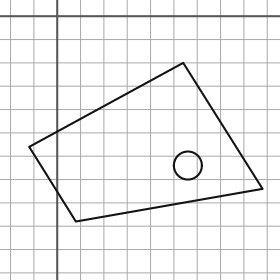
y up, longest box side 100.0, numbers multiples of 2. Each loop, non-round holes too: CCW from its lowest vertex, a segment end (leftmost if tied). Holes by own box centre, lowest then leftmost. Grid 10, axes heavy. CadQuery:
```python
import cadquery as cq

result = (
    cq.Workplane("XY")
    .moveTo(8.0, -88.0)
    .lineTo(88.0, -74.0)
    .lineTo(54.0, -20.0)
    .lineTo(-12.0, -56.0)
    .close()
    .moveTo(56.0, -64.0)
    .circle(6.0)
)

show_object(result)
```